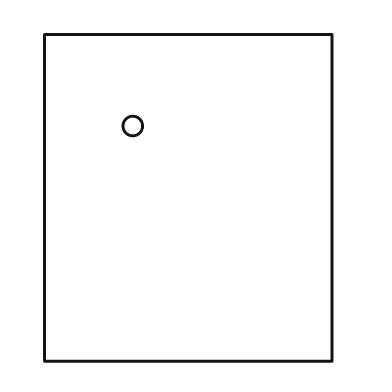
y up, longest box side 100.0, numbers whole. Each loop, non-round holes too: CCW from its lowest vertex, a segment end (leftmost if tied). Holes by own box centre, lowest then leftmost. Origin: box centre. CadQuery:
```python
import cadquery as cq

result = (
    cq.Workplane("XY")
    .moveTo(-44.0, -50.0)
    .lineTo(44.0, -50.0)
    .lineTo(44.0, 50.0)
    .lineTo(-44.0, 50.0)
    .close()
    .moveTo(-17.0, 22.0)
    .circle(3.0)
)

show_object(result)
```